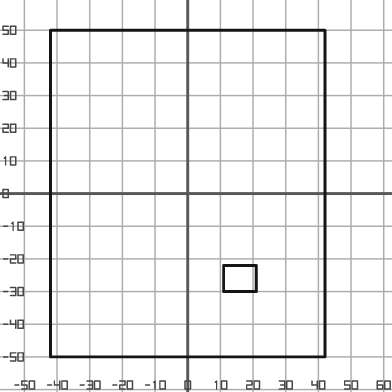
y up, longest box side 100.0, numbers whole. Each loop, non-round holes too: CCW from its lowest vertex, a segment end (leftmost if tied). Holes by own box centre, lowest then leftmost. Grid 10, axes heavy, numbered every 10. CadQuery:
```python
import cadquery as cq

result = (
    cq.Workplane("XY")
    .moveTo(-42.0, -50.0)
    .lineTo(42.0, -50.0)
    .lineTo(42.0, 50.0)
    .lineTo(-42.0, 50.0)
    .close()
    .moveTo(11.0, -30.0)
    .lineTo(21.0, -30.0)
    .lineTo(21.0, -22.0)
    .lineTo(11.0, -22.0)
    .close()
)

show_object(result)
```